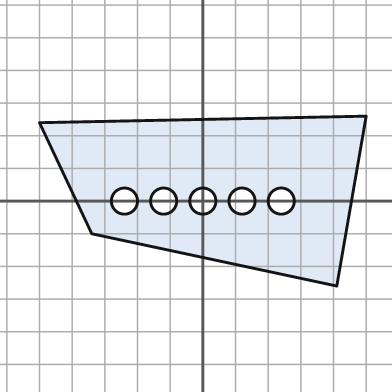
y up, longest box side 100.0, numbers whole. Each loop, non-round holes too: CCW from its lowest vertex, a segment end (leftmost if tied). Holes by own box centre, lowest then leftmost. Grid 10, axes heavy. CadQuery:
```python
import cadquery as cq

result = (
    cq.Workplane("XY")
    .moveTo(41.0, -26.0)
    .lineTo(50.0, 26.0)
    .lineTo(-50.0, 24.0)
    .lineTo(-34.0, -10.0)
    .close()
    .moveTo(-24.0, 0.0)
    .circle(4.0)
    .moveTo(-12.0, 0.0)
    .circle(4.0)
    .moveTo(0.0, 0.0)
    .circle(4.0)
    .moveTo(12.0, 0.0)
    .circle(4.0)
    .moveTo(24.0, 0.0)
    .circle(4.0)
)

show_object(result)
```